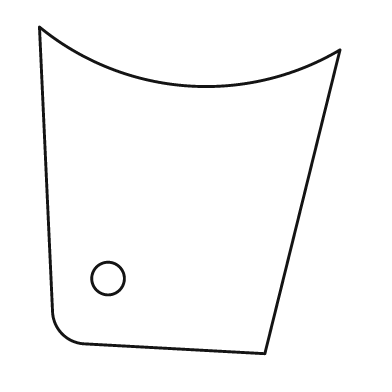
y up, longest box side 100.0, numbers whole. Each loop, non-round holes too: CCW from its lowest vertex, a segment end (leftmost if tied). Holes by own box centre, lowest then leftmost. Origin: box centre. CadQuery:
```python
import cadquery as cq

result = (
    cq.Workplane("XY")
    .moveTo(23.0, -50.0)
    .lineTo(46.0, 43.0)
    .threePointArc((-1.0, 32.0), (-46.0, 50.0))
    .lineTo(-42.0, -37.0)
    .threePointArc((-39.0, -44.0), (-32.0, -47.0))
    .close()
    .moveTo(-25.0, -27.0)
    .circle(5.0)
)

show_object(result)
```